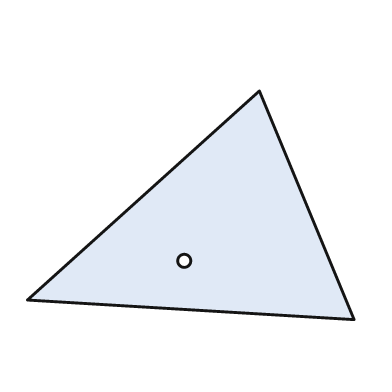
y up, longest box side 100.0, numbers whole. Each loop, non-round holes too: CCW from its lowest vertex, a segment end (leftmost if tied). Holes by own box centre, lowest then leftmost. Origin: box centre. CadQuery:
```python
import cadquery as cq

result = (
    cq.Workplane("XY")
    .moveTo(50.0, -35.0)
    .lineTo(21.0, 35.0)
    .lineTo(-50.0, -29.0)
    .close()
    .moveTo(-2.0, -17.0)
    .circle(2.0)
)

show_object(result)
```